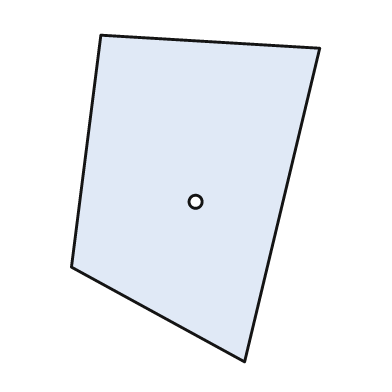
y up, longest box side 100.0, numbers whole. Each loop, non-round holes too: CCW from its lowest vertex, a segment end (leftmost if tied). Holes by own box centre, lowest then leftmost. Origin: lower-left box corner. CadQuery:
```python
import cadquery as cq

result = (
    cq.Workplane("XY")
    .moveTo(53.0, 0.0)
    .lineTo(76.0, 96.0)
    .lineTo(9.0, 100.0)
    .lineTo(0.0, 29.0)
    .close()
    .moveTo(38.0, 49.0)
    .circle(2.0)
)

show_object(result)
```